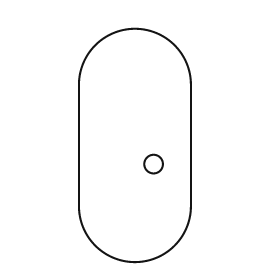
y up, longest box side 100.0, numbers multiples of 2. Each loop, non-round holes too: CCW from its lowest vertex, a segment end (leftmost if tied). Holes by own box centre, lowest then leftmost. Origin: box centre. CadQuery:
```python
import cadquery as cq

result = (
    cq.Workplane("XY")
    .moveTo(-24.0, -26.0)
    .threePointArc((0.0, -50.0), (24.0, -26.0))
    .lineTo(24.0, 26.0)
    .threePointArc((0.0, 50.0), (-24.0, 26.0))
    .close()
    .moveTo(8.0, -8.0)
    .circle(4.0)
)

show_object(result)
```